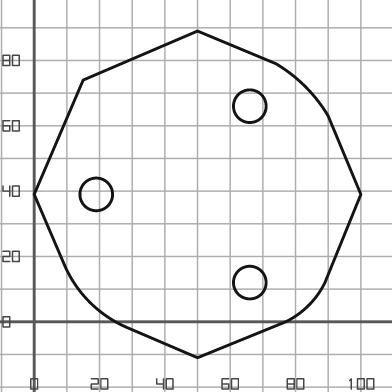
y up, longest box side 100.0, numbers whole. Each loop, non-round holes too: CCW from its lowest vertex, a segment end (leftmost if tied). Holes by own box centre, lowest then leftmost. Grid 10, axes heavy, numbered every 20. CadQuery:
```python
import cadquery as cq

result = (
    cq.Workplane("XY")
    .moveTo(50.0, -11.0)
    .lineTo(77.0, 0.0)
    .threePointArc((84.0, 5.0), (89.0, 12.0))
    .lineTo(100.0, 39.0)
    .lineTo(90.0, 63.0)
    .threePointArc((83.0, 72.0), (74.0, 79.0))
    .lineTo(50.0, 89.0)
    .lineTo(15.0, 74.0)
    .lineTo(0.0, 39.0)
    .lineTo(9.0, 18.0)
    .threePointArc((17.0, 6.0), (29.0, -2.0))
    .close()
    .moveTo(66.0, 12.0)
    .circle(5.0)
    .moveTo(19.0, 39.0)
    .circle(5.0)
    .moveTo(66.0, 66.0)
    .circle(5.0)
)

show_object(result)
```